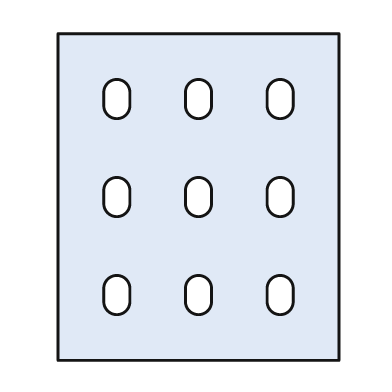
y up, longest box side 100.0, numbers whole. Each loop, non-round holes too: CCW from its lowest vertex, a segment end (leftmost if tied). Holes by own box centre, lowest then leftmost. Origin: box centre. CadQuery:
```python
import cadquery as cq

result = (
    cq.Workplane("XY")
    .moveTo(-43.0, -50.0)
    .lineTo(43.0, -50.0)
    .lineTo(43.0, 50.0)
    .lineTo(-43.0, 50.0)
    .close()
    .moveTo(-29.0, -32.0)
    .threePointArc((-25.0, -36.0), (-21.0, -32.0))
    .lineTo(-21.0, -28.0)
    .threePointArc((-25.0, -24.0), (-29.0, -28.0))
    .close()
    .moveTo(-4.0, -32.0)
    .threePointArc((0.0, -36.0), (4.0, -32.0))
    .lineTo(4.0, -28.0)
    .threePointArc((0.0, -24.0), (-4.0, -28.0))
    .close()
    .moveTo(21.0, -32.0)
    .threePointArc((25.0, -36.0), (29.0, -32.0))
    .lineTo(29.0, -28.0)
    .threePointArc((25.0, -24.0), (21.0, -28.0))
    .close()
    .moveTo(-29.0, -2.0)
    .threePointArc((-25.0, -6.0), (-21.0, -2.0))
    .lineTo(-21.0, 2.0)
    .threePointArc((-25.0, 6.0), (-29.0, 2.0))
    .close()
    .moveTo(-4.0, -2.0)
    .threePointArc((0.0, -6.0), (4.0, -2.0))
    .lineTo(4.0, 2.0)
    .threePointArc((0.0, 6.0), (-4.0, 2.0))
    .close()
    .moveTo(21.0, -2.0)
    .threePointArc((25.0, -6.0), (29.0, -2.0))
    .lineTo(29.0, 2.0)
    .threePointArc((25.0, 6.0), (21.0, 2.0))
    .close()
    .moveTo(-29.0, 28.0)
    .threePointArc((-25.0, 24.0), (-21.0, 28.0))
    .lineTo(-21.0, 32.0)
    .threePointArc((-25.0, 36.0), (-29.0, 32.0))
    .close()
    .moveTo(-4.0, 28.0)
    .threePointArc((0.0, 24.0), (4.0, 28.0))
    .lineTo(4.0, 32.0)
    .threePointArc((0.0, 36.0), (-4.0, 32.0))
    .close()
    .moveTo(21.0, 28.0)
    .threePointArc((25.0, 24.0), (29.0, 28.0))
    .lineTo(29.0, 32.0)
    .threePointArc((25.0, 36.0), (21.0, 32.0))
    .close()
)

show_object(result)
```